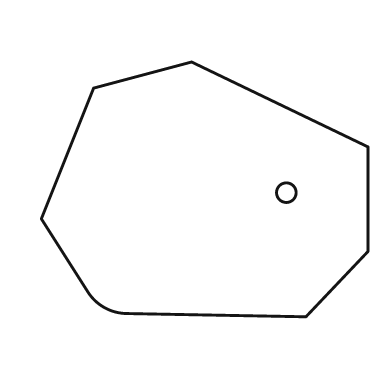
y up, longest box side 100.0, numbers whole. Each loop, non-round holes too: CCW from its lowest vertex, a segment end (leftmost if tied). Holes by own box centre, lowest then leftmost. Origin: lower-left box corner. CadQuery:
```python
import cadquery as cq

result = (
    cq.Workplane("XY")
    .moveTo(81.0, 0.0)
    .lineTo(100.0, 20.0)
    .lineTo(100.0, 52.0)
    .lineTo(46.0, 78.0)
    .lineTo(16.0, 70.0)
    .lineTo(0.0, 30.0)
    .lineTo(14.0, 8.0)
    .threePointArc((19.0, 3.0), (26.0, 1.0))
    .close()
    .moveTo(75.0, 38.0)
    .circle(3.0)
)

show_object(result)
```